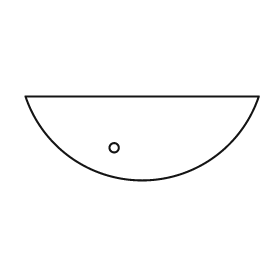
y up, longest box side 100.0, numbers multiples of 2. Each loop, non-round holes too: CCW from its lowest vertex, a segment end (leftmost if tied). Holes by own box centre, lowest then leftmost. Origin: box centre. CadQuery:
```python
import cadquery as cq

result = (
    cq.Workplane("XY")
    .moveTo(-50.0, 18.0)
    .threePointArc((0.0, -18.0), (50.0, 18.0))
    .close()
    .moveTo(-12.0, -4.0)
    .circle(2.0)
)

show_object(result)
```